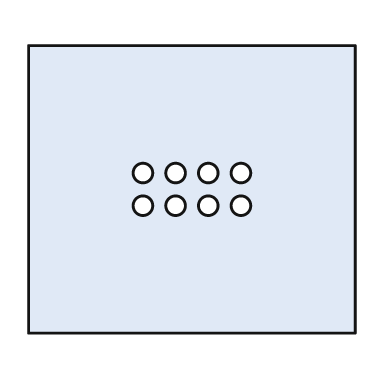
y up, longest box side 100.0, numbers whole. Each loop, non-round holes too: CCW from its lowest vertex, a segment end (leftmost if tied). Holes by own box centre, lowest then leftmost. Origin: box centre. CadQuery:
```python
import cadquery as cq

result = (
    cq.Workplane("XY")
    .moveTo(-50.0, -44.0)
    .lineTo(50.0, -44.0)
    .lineTo(50.0, 44.0)
    .lineTo(-50.0, 44.0)
    .close()
    .moveTo(-15.0, -5.0)
    .circle(3.0)
    .moveTo(-5.0, -5.0)
    .circle(3.0)
    .moveTo(5.0, -5.0)
    .circle(3.0)
    .moveTo(15.0, -5.0)
    .circle(3.0)
    .moveTo(-15.0, 5.0)
    .circle(3.0)
    .moveTo(-5.0, 5.0)
    .circle(3.0)
    .moveTo(5.0, 5.0)
    .circle(3.0)
    .moveTo(15.0, 5.0)
    .circle(3.0)
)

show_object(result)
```